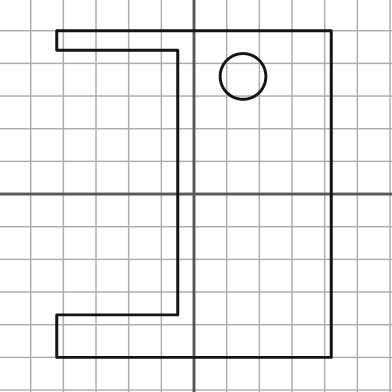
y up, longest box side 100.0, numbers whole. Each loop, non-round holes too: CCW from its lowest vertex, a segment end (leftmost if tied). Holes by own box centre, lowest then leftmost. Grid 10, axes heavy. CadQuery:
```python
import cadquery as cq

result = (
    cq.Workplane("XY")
    .moveTo(-42.0, -50.0)
    .lineTo(42.0, -50.0)
    .lineTo(42.0, 50.0)
    .lineTo(-42.0, 50.0)
    .lineTo(-42.0, 44.0)
    .lineTo(-5.0, 44.0)
    .lineTo(-5.0, -37.0)
    .lineTo(-42.0, -37.0)
    .close()
    .moveTo(15.0, 36.0)
    .circle(7.0)
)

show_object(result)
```